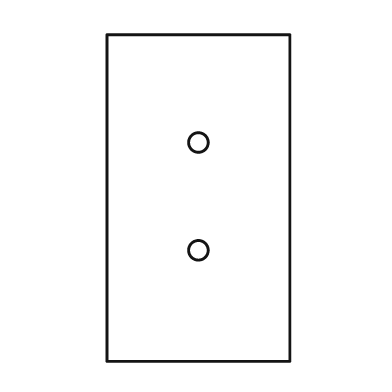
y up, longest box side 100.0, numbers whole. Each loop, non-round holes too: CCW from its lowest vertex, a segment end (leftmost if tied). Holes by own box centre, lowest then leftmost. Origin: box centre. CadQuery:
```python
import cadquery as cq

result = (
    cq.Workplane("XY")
    .moveTo(-28.0, -50.0)
    .lineTo(28.0, -50.0)
    .lineTo(28.0, 50.0)
    .lineTo(-28.0, 50.0)
    .close()
    .moveTo(0.0, -16.0)
    .circle(3.0)
    .moveTo(0.0, 17.0)
    .circle(3.0)
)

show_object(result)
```